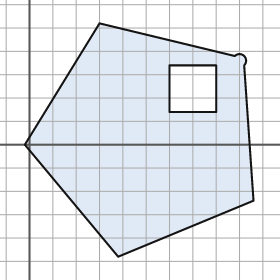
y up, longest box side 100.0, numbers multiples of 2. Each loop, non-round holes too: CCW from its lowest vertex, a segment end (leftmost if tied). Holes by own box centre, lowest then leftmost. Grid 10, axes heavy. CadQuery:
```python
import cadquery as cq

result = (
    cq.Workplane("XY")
    .moveTo(38.0, -48.0)
    .lineTo(96.0, -24.0)
    .lineTo(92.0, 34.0)
    .threePointArc((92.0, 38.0), (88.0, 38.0))
    .lineTo(30.0, 52.0)
    .lineTo(-2.0, 0.0)
    .close()
    .moveTo(60.0, 14.0)
    .lineTo(80.0, 14.0)
    .lineTo(80.0, 34.0)
    .lineTo(60.0, 34.0)
    .close()
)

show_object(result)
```